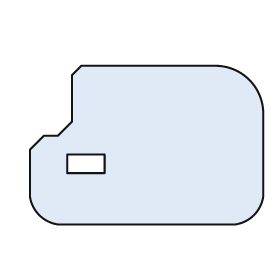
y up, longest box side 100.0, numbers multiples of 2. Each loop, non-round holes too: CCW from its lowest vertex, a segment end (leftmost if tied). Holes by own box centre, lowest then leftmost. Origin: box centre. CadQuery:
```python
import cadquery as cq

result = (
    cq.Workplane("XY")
    .moveTo(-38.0, -34.0)
    .lineTo(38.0, -34.0)
    .threePointArc((46.0, -30.0), (50.0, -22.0))
    .lineTo(50.0, 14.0)
    .threePointArc((44.0, 28.0), (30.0, 34.0))
    .lineTo(-28.0, 34.0)
    .lineTo(-32.0, 30.0)
    .lineTo(-32.0, 10.0)
    .lineTo(-38.0, 4.0)
    .lineTo(-44.0, 4.0)
    .lineTo(-50.0, -2.0)
    .lineTo(-50.0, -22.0)
    .threePointArc((-46.0, -30.0), (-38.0, -34.0))
    .close()
    .moveTo(-34.0, -12.0)
    .lineTo(-18.0, -12.0)
    .lineTo(-18.0, -4.0)
    .lineTo(-34.0, -4.0)
    .close()
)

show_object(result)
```